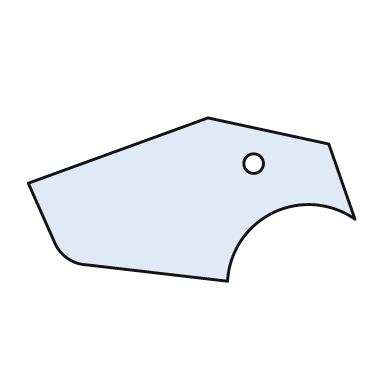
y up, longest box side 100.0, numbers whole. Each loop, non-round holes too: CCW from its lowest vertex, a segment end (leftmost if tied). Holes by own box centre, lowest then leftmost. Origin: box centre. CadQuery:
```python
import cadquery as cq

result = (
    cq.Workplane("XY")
    .moveTo(11.0, -25.0)
    .threePointArc((25.0, -4.0), (50.0, -6.0))
    .lineTo(42.0, 17.0)
    .lineTo(5.0, 25.0)
    .lineTo(-50.0, 5.0)
    .lineTo(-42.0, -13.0)
    .threePointArc((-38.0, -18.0), (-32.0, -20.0))
    .close()
    .moveTo(19.0, 11.0)
    .circle(3.0)
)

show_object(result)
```